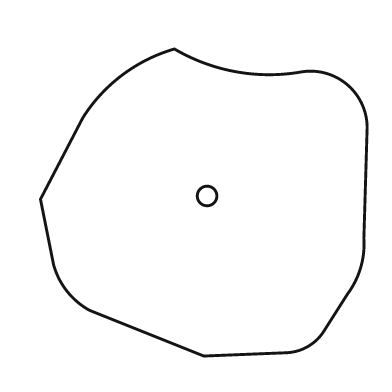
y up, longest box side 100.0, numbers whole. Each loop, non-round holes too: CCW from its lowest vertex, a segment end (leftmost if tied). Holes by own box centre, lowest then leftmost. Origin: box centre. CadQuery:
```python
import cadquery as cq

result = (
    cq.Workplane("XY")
    .moveTo(0.0, -47.0)
    .lineTo(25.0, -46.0)
    .threePointArc((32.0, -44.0), (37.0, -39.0))
    .lineTo(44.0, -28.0)
    .threePointArc((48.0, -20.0), (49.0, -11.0))
    .lineTo(50.0, 23.0)
    .threePointArc((44.0, 36.0), (30.0, 40.0))
    .threePointArc((10.0, 40.0), (-9.0, 47.0))
    .threePointArc((-25.0, 39.0), (-37.0, 26.0))
    .lineTo(-50.0, 1.0)
    .lineTo(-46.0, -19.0)
    .threePointArc((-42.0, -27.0), (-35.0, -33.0))
    .close()
    .moveTo(1.0, 2.0)
    .circle(3.0)
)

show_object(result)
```